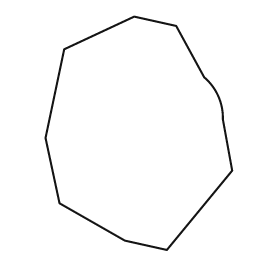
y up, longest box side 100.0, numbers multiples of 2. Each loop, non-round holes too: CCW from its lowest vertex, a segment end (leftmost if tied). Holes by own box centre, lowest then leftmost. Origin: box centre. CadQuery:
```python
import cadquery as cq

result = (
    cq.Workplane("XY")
    .moveTo(12.0, -50.0)
    .lineTo(40.0, -16.0)
    .lineTo(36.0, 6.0)
    .threePointArc((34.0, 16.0), (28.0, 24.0))
    .lineTo(16.0, 46.0)
    .lineTo(-2.0, 50.0)
    .lineTo(-32.0, 36.0)
    .lineTo(-40.0, -2.0)
    .lineTo(-34.0, -30.0)
    .lineTo(-6.0, -46.0)
    .close()
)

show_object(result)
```